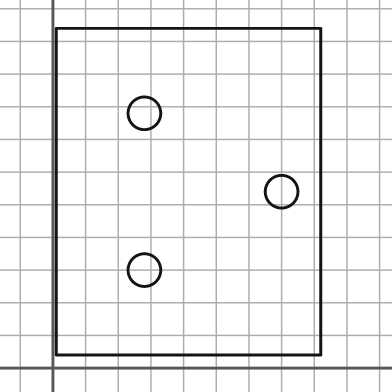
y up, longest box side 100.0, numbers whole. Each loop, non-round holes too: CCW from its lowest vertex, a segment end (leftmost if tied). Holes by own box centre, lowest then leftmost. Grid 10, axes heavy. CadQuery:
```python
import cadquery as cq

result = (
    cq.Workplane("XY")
    .moveTo(1.0, 4.0)
    .lineTo(82.0, 4.0)
    .lineTo(82.0, 104.0)
    .lineTo(1.0, 104.0)
    .close()
    .moveTo(28.0, 30.0)
    .circle(5.0)
    .moveTo(70.0, 54.0)
    .circle(5.0)
    .moveTo(28.0, 78.0)
    .circle(5.0)
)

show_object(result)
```